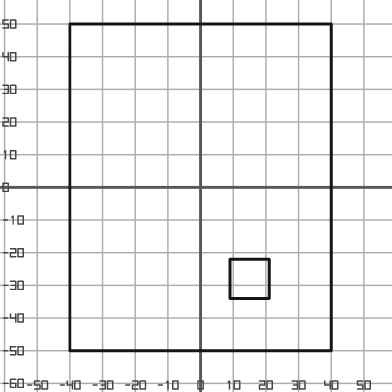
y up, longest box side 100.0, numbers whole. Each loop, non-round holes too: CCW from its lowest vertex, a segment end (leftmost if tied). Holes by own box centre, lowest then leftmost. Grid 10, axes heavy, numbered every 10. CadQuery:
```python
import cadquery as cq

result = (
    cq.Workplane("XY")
    .moveTo(-40.0, -50.0)
    .lineTo(40.0, -50.0)
    .lineTo(40.0, 50.0)
    .lineTo(-40.0, 50.0)
    .close()
    .moveTo(9.0, -34.0)
    .lineTo(21.0, -34.0)
    .lineTo(21.0, -22.0)
    .lineTo(9.0, -22.0)
    .close()
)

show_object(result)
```